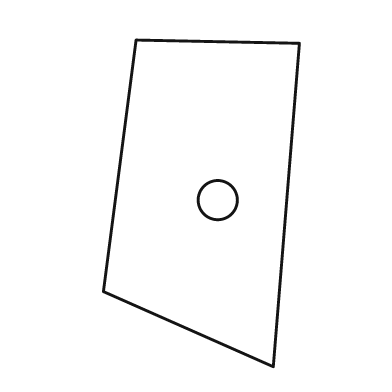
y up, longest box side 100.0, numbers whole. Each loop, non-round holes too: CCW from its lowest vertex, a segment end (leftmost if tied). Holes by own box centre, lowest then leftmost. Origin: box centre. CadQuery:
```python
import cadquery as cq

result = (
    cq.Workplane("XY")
    .moveTo(22.0, -50.0)
    .lineTo(30.0, 49.0)
    .lineTo(-20.0, 50.0)
    .lineTo(-30.0, -27.0)
    .close()
    .moveTo(5.0, 1.0)
    .circle(6.0)
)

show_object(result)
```